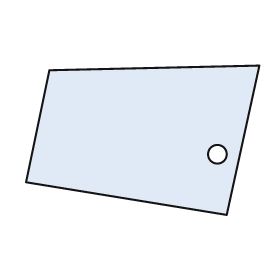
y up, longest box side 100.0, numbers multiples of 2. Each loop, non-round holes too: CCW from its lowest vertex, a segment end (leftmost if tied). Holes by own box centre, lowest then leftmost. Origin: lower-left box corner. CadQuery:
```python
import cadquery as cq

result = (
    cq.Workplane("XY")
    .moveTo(86.0, 0.0)
    .lineTo(100.0, 64.0)
    .lineTo(10.0, 62.0)
    .lineTo(0.0, 14.0)
    .close()
    .moveTo(82.0, 26.0)
    .circle(4.0)
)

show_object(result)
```